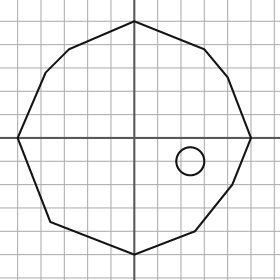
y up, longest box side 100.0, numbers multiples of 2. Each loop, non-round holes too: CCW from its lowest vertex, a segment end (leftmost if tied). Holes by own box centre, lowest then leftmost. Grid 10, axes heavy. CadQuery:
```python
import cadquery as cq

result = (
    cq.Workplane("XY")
    .moveTo(0.0, -50.0)
    .lineTo(26.0, -40.0)
    .lineTo(42.0, -20.0)
    .lineTo(50.0, 0.0)
    .lineTo(40.0, 26.0)
    .lineTo(30.0, 38.0)
    .lineTo(0.0, 50.0)
    .lineTo(-28.0, 38.0)
    .lineTo(-38.0, 28.0)
    .lineTo(-50.0, 0.0)
    .lineTo(-36.0, -36.0)
    .close()
    .moveTo(24.0, -10.0)
    .circle(6.0)
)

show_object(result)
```